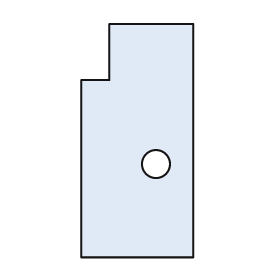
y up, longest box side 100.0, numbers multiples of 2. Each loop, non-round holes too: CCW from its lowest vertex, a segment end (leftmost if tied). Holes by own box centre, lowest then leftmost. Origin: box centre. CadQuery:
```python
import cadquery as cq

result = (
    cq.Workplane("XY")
    .moveTo(-24.0, -50.0)
    .lineTo(24.0, -50.0)
    .lineTo(24.0, 50.0)
    .lineTo(-12.0, 50.0)
    .lineTo(-12.0, 26.0)
    .lineTo(-24.0, 26.0)
    .close()
    .moveTo(8.0, -10.0)
    .circle(6.0)
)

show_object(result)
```